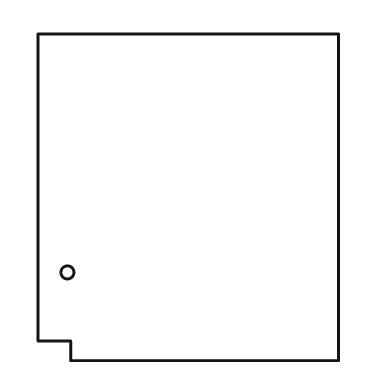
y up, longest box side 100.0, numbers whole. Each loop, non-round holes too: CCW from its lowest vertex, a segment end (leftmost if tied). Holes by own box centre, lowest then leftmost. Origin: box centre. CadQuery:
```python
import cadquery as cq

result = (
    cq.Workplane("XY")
    .moveTo(-36.0, -50.0)
    .lineTo(46.0, -50.0)
    .lineTo(46.0, 50.0)
    .lineTo(-46.0, 50.0)
    .lineTo(-46.0, -44.0)
    .lineTo(-36.0, -44.0)
    .close()
    .moveTo(-37.0, -23.0)
    .circle(2.0)
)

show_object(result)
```